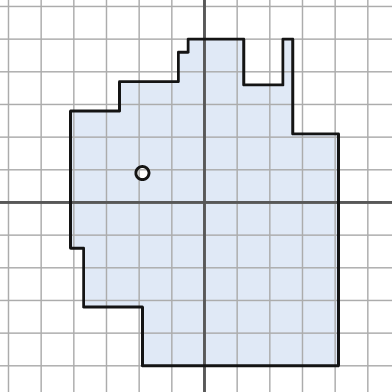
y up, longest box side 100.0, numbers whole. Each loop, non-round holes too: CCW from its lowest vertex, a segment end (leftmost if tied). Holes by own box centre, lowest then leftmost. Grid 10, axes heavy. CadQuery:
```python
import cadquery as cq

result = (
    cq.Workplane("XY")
    .moveTo(-19.0, -50.0)
    .lineTo(41.0, -50.0)
    .lineTo(41.0, 21.0)
    .lineTo(27.0, 21.0)
    .lineTo(27.0, 50.0)
    .lineTo(24.0, 50.0)
    .lineTo(24.0, 36.0)
    .lineTo(12.0, 36.0)
    .lineTo(12.0, 50.0)
    .lineTo(-5.0, 50.0)
    .lineTo(-5.0, 46.0)
    .lineTo(-8.0, 46.0)
    .lineTo(-8.0, 37.0)
    .lineTo(-26.0, 37.0)
    .lineTo(-26.0, 28.0)
    .lineTo(-41.0, 28.0)
    .lineTo(-41.0, -14.0)
    .lineTo(-37.0, -14.0)
    .lineTo(-37.0, -32.0)
    .lineTo(-19.0, -32.0)
    .close()
    .moveTo(-19.0, 9.0)
    .circle(2.0)
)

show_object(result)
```